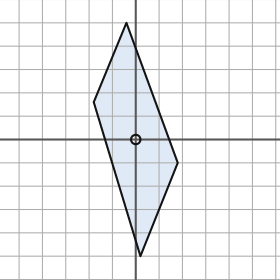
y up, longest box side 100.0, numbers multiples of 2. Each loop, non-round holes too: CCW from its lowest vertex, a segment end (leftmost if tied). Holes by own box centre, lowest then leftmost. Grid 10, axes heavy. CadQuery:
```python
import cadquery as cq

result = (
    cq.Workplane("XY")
    .moveTo(2.0, -50.0)
    .lineTo(18.0, -10.0)
    .lineTo(-4.0, 50.0)
    .lineTo(-18.0, 16.0)
    .close()
    .moveTo(0.0, 0.0)
    .circle(2.0)
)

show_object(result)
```